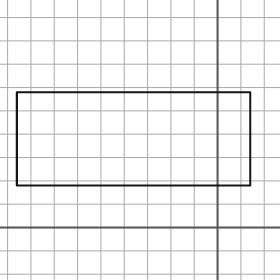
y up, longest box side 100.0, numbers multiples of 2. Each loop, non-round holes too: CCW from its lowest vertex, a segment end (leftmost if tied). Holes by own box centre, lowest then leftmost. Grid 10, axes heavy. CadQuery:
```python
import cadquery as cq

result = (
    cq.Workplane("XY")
    .moveTo(-86.0, 18.0)
    .lineTo(14.0, 18.0)
    .lineTo(14.0, 58.0)
    .lineTo(-86.0, 58.0)
    .close()
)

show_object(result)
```